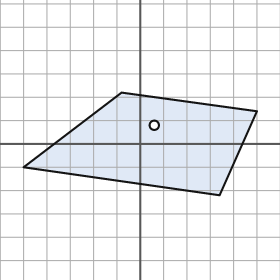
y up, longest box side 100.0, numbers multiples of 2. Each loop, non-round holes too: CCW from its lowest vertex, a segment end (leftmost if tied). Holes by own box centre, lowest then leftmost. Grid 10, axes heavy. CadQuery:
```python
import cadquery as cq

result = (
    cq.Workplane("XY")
    .moveTo(34.0, -22.0)
    .lineTo(50.0, 14.0)
    .lineTo(-8.0, 22.0)
    .lineTo(-50.0, -10.0)
    .close()
    .moveTo(6.0, 8.0)
    .circle(2.0)
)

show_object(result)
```